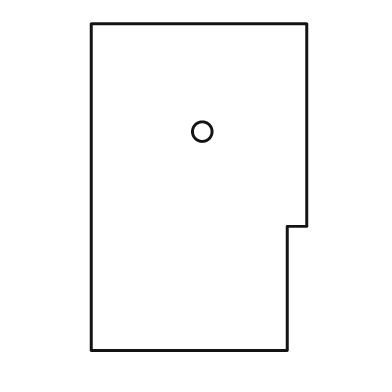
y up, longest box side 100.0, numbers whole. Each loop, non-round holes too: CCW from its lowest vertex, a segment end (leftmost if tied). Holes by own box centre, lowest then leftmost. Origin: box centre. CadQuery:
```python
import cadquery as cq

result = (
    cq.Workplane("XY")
    .moveTo(-33.0, -50.0)
    .lineTo(27.0, -50.0)
    .lineTo(27.0, -12.0)
    .lineTo(33.0, -12.0)
    .lineTo(33.0, 50.0)
    .lineTo(-33.0, 50.0)
    .close()
    .moveTo(1.0, 17.0)
    .circle(3.0)
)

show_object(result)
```